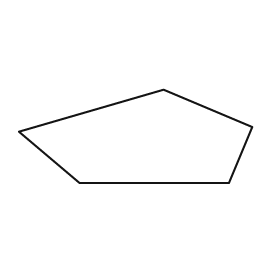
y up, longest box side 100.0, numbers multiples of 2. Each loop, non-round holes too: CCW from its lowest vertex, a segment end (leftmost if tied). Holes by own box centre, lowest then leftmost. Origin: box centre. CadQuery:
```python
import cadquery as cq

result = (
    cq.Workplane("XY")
    .moveTo(-24.0, -20.0)
    .lineTo(40.0, -20.0)
    .lineTo(50.0, 4.0)
    .lineTo(12.0, 20.0)
    .lineTo(-50.0, 2.0)
    .close()
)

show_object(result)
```